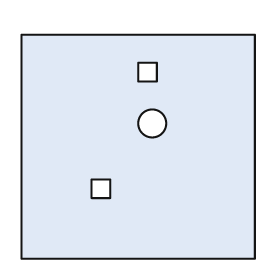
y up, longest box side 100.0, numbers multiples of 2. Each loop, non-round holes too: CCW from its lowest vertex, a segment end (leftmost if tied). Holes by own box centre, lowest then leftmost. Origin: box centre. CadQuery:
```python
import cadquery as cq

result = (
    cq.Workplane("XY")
    .moveTo(-50.0, -48.0)
    .lineTo(50.0, -48.0)
    .lineTo(50.0, 48.0)
    .lineTo(-50.0, 48.0)
    .close()
    .moveTo(-20.0, -22.0)
    .lineTo(-12.0, -22.0)
    .lineTo(-12.0, -14.0)
    .lineTo(-20.0, -14.0)
    .close()
    .moveTo(6.0, 10.0)
    .circle(6.0)
    .moveTo(0.0, 28.0)
    .lineTo(8.0, 28.0)
    .lineTo(8.0, 36.0)
    .lineTo(0.0, 36.0)
    .close()
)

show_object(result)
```